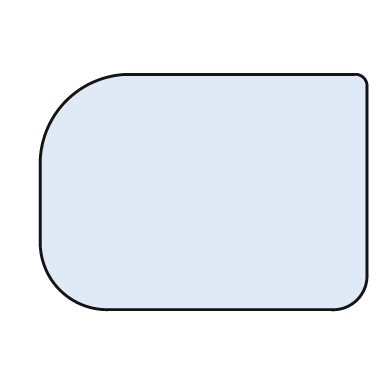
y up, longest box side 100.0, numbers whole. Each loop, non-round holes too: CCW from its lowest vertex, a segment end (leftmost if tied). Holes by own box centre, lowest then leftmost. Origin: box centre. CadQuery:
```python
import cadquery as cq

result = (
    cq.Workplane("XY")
    .moveTo(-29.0, -36.0)
    .lineTo(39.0, -36.0)
    .threePointArc((47.0, -33.0), (50.0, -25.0))
    .lineTo(50.0, 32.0)
    .threePointArc((49.0, 35.0), (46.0, 36.0))
    .lineTo(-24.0, 36.0)
    .threePointArc((-42.0, 28.0), (-50.0, 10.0))
    .lineTo(-50.0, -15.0)
    .threePointArc((-44.0, -30.0), (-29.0, -36.0))
    .close()
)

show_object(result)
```